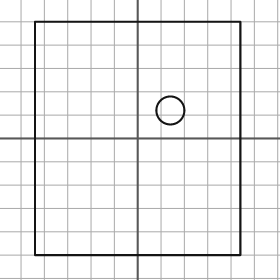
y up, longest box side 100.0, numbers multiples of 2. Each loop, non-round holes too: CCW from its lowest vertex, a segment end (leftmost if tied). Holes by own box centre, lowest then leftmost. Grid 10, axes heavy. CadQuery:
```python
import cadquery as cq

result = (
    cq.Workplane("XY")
    .moveTo(-44.0, -50.0)
    .lineTo(44.0, -50.0)
    .lineTo(44.0, 50.0)
    .lineTo(-44.0, 50.0)
    .close()
    .moveTo(14.0, 12.0)
    .circle(6.0)
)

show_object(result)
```